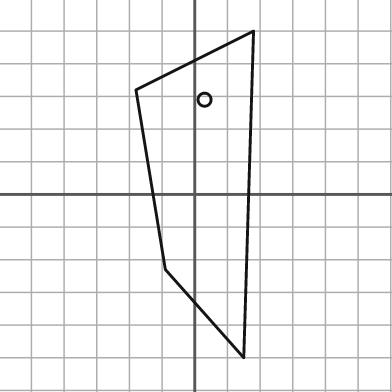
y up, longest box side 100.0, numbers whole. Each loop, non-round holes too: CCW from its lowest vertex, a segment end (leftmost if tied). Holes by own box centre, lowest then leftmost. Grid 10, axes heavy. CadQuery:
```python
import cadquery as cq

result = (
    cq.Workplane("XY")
    .moveTo(15.0, -50.0)
    .lineTo(18.0, 50.0)
    .lineTo(-18.0, 32.0)
    .lineTo(-9.0, -23.0)
    .close()
    .moveTo(3.0, 29.0)
    .circle(2.0)
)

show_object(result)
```